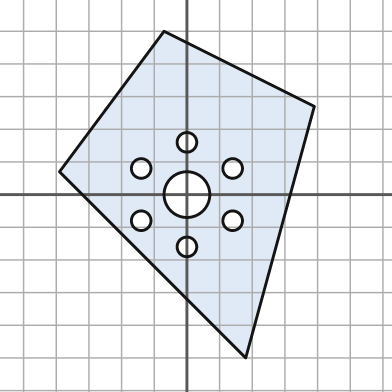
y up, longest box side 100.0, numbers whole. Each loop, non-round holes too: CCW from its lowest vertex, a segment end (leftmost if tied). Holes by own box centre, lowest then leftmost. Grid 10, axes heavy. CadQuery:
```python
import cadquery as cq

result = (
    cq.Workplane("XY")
    .moveTo(18.0, -50.0)
    .lineTo(39.0, 27.0)
    .lineTo(-7.0, 50.0)
    .lineTo(-39.0, 7.0)
    .close()
    .moveTo(0.0, -16.0)
    .circle(3.0)
    .moveTo(-14.0, -8.0)
    .circle(3.0)
    .moveTo(14.0, -8.0)
    .circle(3.0)
    .moveTo(0.0, 0.0)
    .circle(7.0)
    .moveTo(-14.0, 8.0)
    .circle(3.0)
    .moveTo(14.0, 8.0)
    .circle(3.0)
    .moveTo(0.0, 16.0)
    .circle(3.0)
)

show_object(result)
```